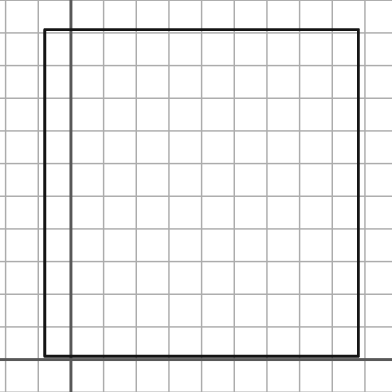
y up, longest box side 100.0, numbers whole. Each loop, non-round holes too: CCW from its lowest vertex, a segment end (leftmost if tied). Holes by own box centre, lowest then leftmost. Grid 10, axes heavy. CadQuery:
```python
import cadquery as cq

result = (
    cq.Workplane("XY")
    .moveTo(-8.0, 1.0)
    .lineTo(88.0, 1.0)
    .lineTo(88.0, 101.0)
    .lineTo(-8.0, 101.0)
    .close()
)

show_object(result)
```